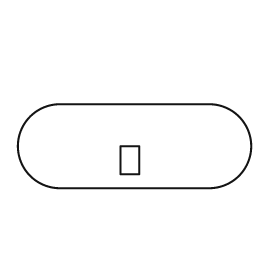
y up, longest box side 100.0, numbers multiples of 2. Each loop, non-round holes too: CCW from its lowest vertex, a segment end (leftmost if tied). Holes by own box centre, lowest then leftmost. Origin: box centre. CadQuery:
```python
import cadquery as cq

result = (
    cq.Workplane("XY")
    .moveTo(-32.0, -18.0)
    .lineTo(32.0, -18.0)
    .threePointArc((50.0, 0.0), (32.0, 18.0))
    .lineTo(-32.0, 18.0)
    .threePointArc((-50.0, 0.0), (-32.0, -18.0))
    .close()
    .moveTo(-6.0, -12.0)
    .lineTo(2.0, -12.0)
    .lineTo(2.0, 0.0)
    .lineTo(-6.0, 0.0)
    .close()
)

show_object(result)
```